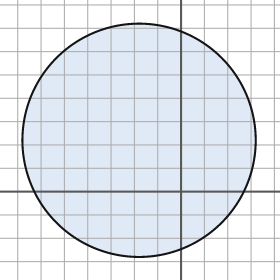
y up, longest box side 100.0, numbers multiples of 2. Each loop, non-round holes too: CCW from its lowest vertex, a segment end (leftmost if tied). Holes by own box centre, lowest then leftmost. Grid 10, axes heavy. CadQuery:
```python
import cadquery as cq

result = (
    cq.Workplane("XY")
    .moveTo(-18.0, 22.0)
    .circle(50.0)
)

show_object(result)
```